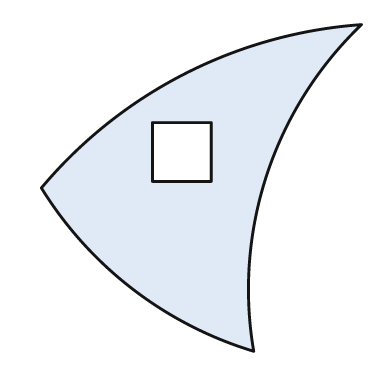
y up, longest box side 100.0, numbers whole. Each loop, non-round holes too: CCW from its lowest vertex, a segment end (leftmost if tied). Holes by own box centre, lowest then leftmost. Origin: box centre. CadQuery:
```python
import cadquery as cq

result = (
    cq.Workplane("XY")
    .moveTo(16.0, -50.0)
    .threePointArc((20.0, 4.0), (49.0, 50.0))
    .threePointArc((-5.0, 35.0), (-49.0, 0.0))
    .threePointArc((-21.0, -31.0), (16.0, -50.0))
    .close()
    .moveTo(-15.0, 2.0)
    .lineTo(3.0, 2.0)
    .lineTo(3.0, 20.0)
    .lineTo(-15.0, 20.0)
    .close()
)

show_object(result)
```